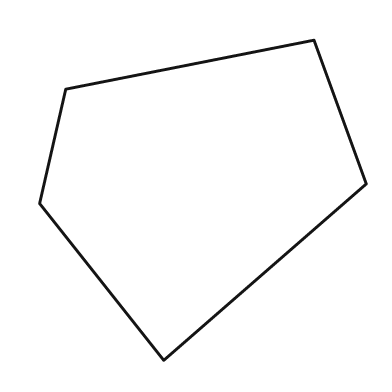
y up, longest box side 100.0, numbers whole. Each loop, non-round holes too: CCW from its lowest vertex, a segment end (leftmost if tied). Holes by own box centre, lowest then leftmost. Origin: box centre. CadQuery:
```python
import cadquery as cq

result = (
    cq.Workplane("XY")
    .moveTo(-12.0, -49.0)
    .lineTo(50.0, 5.0)
    .lineTo(34.0, 49.0)
    .lineTo(-42.0, 34.0)
    .lineTo(-50.0, -1.0)
    .close()
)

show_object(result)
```